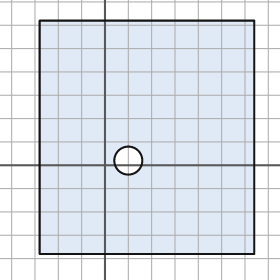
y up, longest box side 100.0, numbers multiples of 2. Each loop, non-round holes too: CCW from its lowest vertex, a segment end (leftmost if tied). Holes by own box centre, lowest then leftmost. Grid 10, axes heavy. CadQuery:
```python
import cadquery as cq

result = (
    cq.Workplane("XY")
    .moveTo(-28.0, -38.0)
    .lineTo(64.0, -38.0)
    .lineTo(64.0, 62.0)
    .lineTo(-28.0, 62.0)
    .close()
    .moveTo(10.0, 2.0)
    .circle(6.0)
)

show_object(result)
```